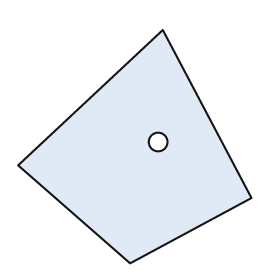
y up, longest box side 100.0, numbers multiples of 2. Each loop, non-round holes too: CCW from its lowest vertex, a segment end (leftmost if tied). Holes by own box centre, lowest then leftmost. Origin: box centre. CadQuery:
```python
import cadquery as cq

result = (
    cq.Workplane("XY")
    .moveTo(-2.0, -50.0)
    .lineTo(50.0, -22.0)
    .lineTo(12.0, 50.0)
    .lineTo(-50.0, -8.0)
    .close()
    .moveTo(10.0, 2.0)
    .circle(4.0)
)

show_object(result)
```